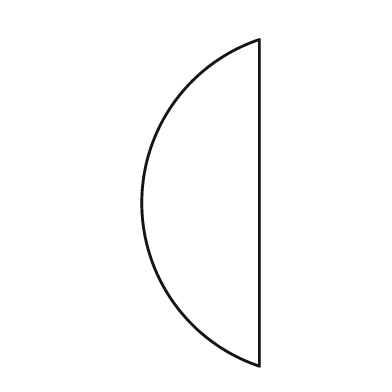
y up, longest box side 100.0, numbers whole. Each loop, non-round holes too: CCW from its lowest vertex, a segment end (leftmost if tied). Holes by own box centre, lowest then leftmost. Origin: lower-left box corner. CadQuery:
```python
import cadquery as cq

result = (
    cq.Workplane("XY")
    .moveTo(36.0, 0.0)
    .lineTo(36.0, 100.0)
    .threePointArc((0.0, 50.0), (36.0, 0.0))
    .close()
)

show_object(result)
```